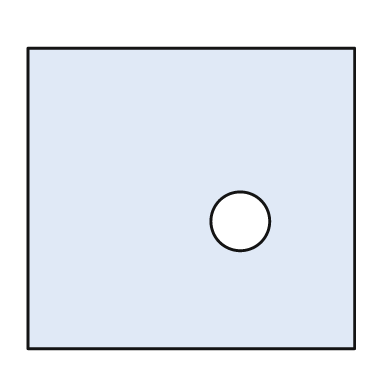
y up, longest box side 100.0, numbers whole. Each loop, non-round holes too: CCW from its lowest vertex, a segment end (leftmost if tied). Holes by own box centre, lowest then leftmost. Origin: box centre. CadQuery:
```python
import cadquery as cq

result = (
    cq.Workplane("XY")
    .moveTo(-50.0, -46.0)
    .lineTo(50.0, -46.0)
    .lineTo(50.0, 46.0)
    .lineTo(-50.0, 46.0)
    .close()
    .moveTo(15.0, -7.0)
    .circle(9.0)
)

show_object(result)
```